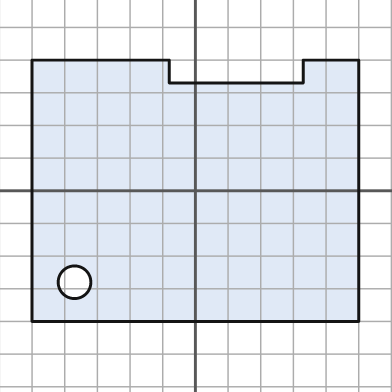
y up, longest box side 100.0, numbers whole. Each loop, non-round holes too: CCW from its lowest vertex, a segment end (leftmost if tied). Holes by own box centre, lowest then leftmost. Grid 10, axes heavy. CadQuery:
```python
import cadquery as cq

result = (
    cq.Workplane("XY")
    .moveTo(-50.0, -40.0)
    .lineTo(50.0, -40.0)
    .lineTo(50.0, 40.0)
    .lineTo(33.0, 40.0)
    .lineTo(33.0, 33.0)
    .lineTo(-8.0, 33.0)
    .lineTo(-8.0, 40.0)
    .lineTo(-50.0, 40.0)
    .close()
    .moveTo(-37.0, -28.0)
    .circle(5.0)
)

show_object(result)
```